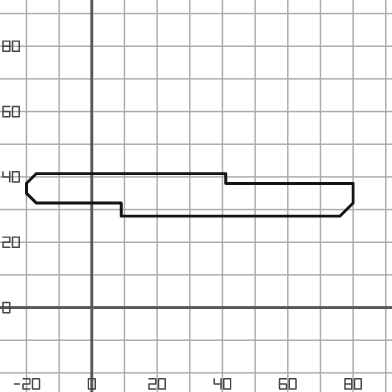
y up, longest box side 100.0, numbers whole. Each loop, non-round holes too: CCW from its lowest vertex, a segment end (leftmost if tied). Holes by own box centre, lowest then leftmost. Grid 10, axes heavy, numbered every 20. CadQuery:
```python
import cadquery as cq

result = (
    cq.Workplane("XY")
    .moveTo(9.0, 28.0)
    .lineTo(76.0, 28.0)
    .lineTo(80.0, 32.0)
    .lineTo(80.0, 38.0)
    .lineTo(41.0, 38.0)
    .lineTo(41.0, 41.0)
    .lineTo(-17.0, 41.0)
    .lineTo(-20.0, 38.0)
    .lineTo(-20.0, 35.0)
    .lineTo(-17.0, 32.0)
    .lineTo(9.0, 32.0)
    .close()
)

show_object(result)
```